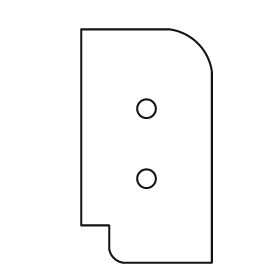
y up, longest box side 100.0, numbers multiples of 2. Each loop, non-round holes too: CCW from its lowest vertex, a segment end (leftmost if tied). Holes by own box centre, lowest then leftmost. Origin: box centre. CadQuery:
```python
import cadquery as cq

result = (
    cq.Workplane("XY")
    .moveTo(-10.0, -50.0)
    .lineTo(28.0, -50.0)
    .lineTo(28.0, 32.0)
    .threePointArc((22.0, 44.0), (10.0, 50.0))
    .lineTo(-28.0, 50.0)
    .lineTo(-28.0, -34.0)
    .lineTo(-16.0, -34.0)
    .lineTo(-16.0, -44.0)
    .threePointArc((-14.0, -48.0), (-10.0, -50.0))
    .close()
    .moveTo(0.0, -14.0)
    .circle(4.0)
    .moveTo(0.0, 16.0)
    .circle(4.0)
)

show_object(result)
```